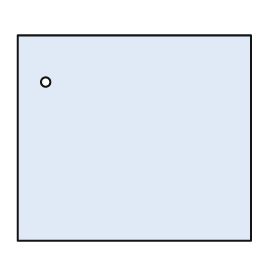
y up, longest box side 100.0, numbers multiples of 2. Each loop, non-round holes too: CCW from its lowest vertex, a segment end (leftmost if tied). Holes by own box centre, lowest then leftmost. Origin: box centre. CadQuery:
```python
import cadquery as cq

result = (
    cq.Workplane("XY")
    .moveTo(-50.0, -44.0)
    .lineTo(50.0, -44.0)
    .lineTo(50.0, 44.0)
    .lineTo(-50.0, 44.0)
    .close()
    .moveTo(-38.0, 24.0)
    .circle(2.0)
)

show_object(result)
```